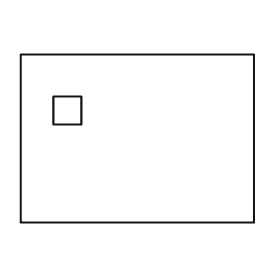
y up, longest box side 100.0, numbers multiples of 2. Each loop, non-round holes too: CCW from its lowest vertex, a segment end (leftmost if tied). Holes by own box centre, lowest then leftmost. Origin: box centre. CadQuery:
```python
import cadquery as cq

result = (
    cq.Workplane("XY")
    .moveTo(-50.0, -36.0)
    .lineTo(50.0, -36.0)
    .lineTo(50.0, 36.0)
    .lineTo(-50.0, 36.0)
    .close()
    .moveTo(-36.0, 6.0)
    .lineTo(-24.0, 6.0)
    .lineTo(-24.0, 18.0)
    .lineTo(-36.0, 18.0)
    .close()
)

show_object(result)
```